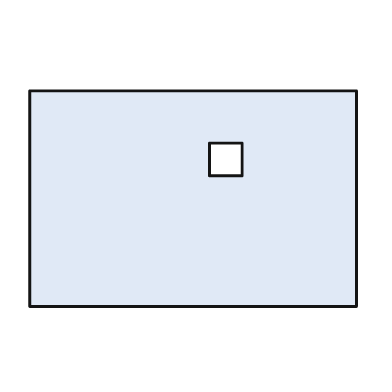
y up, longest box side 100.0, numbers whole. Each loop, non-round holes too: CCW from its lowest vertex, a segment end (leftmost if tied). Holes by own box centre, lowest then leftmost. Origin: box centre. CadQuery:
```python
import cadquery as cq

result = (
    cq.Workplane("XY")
    .moveTo(-50.0, -33.0)
    .lineTo(50.0, -33.0)
    .lineTo(50.0, 33.0)
    .lineTo(-50.0, 33.0)
    .close()
    .moveTo(5.0, 7.0)
    .lineTo(15.0, 7.0)
    .lineTo(15.0, 17.0)
    .lineTo(5.0, 17.0)
    .close()
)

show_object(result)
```